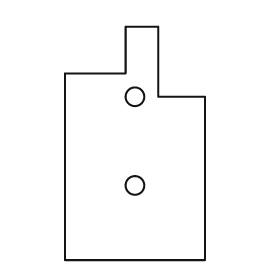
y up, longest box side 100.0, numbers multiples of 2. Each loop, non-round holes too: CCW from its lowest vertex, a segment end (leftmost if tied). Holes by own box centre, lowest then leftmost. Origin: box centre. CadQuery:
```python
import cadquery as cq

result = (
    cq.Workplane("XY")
    .moveTo(-30.0, -50.0)
    .lineTo(30.0, -50.0)
    .lineTo(30.0, 20.0)
    .lineTo(10.0, 20.0)
    .lineTo(10.0, 50.0)
    .lineTo(-4.0, 50.0)
    .lineTo(-4.0, 30.0)
    .lineTo(-30.0, 30.0)
    .close()
    .moveTo(0.0, -18.0)
    .circle(4.0)
    .moveTo(0.0, 20.0)
    .circle(4.0)
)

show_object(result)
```